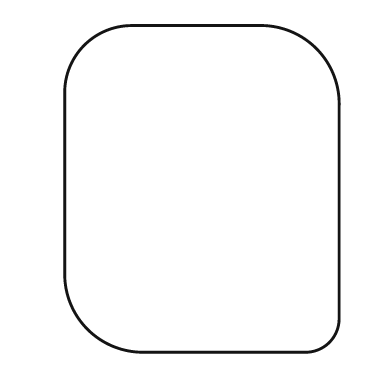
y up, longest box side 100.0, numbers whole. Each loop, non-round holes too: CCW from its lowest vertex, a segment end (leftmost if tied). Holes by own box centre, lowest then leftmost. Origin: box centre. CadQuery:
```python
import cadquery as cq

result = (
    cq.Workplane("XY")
    .moveTo(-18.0, -50.0)
    .lineTo(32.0, -50.0)
    .threePointArc((39.0, -47.0), (42.0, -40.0))
    .lineTo(42.0, 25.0)
    .threePointArc((35.0, 43.0), (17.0, 50.0))
    .lineTo(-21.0, 50.0)
    .threePointArc((-36.0, 44.0), (-42.0, 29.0))
    .lineTo(-42.0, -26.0)
    .threePointArc((-35.0, -43.0), (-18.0, -50.0))
    .close()
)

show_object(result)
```